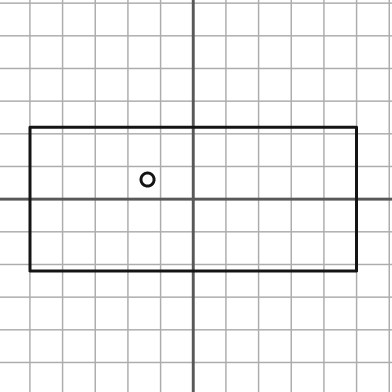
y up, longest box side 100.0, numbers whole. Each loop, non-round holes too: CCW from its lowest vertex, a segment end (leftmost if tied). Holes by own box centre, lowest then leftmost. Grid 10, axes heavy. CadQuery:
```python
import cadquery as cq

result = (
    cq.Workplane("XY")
    .moveTo(-50.0, -22.0)
    .lineTo(50.0, -22.0)
    .lineTo(50.0, 22.0)
    .lineTo(-50.0, 22.0)
    .close()
    .moveTo(-14.0, 6.0)
    .circle(2.0)
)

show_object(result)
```